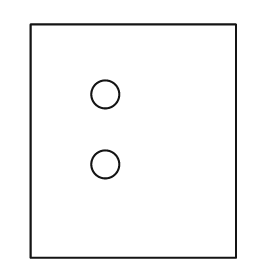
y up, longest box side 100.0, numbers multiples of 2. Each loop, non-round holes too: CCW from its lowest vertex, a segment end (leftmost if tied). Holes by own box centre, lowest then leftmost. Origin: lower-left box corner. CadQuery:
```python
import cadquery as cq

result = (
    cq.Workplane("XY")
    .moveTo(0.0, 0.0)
    .lineTo(88.0, 0.0)
    .lineTo(88.0, 100.0)
    .lineTo(0.0, 100.0)
    .close()
    .moveTo(32.0, 40.0)
    .circle(6.0)
    .moveTo(32.0, 70.0)
    .circle(6.0)
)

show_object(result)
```